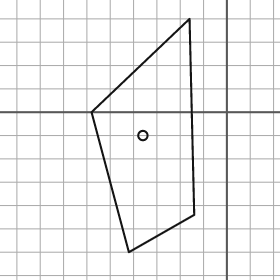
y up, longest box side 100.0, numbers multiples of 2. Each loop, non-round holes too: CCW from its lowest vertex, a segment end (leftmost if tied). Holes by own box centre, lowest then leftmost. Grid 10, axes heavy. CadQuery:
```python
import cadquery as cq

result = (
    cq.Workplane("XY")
    .moveTo(-42.0, -60.0)
    .lineTo(-14.0, -44.0)
    .lineTo(-16.0, 40.0)
    .lineTo(-58.0, 0.0)
    .close()
    .moveTo(-36.0, -10.0)
    .circle(2.0)
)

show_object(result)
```